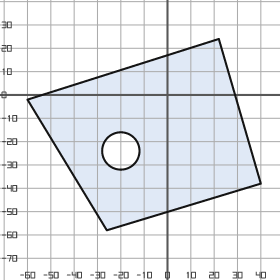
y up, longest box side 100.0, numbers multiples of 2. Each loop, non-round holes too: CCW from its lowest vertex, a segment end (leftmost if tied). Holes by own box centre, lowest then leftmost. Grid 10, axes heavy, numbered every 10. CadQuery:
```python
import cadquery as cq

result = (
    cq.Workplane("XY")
    .moveTo(-26.0, -58.0)
    .lineTo(40.0, -38.0)
    .lineTo(22.0, 24.0)
    .lineTo(-60.0, -2.0)
    .close()
    .moveTo(-20.0, -24.0)
    .circle(8.0)
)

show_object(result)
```